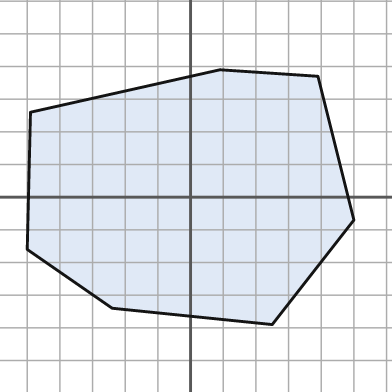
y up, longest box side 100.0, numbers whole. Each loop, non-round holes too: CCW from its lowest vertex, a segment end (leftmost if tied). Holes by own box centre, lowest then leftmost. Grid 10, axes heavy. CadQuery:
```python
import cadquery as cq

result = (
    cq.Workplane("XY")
    .moveTo(25.0, -39.0)
    .lineTo(50.0, -7.0)
    .lineTo(39.0, 37.0)
    .lineTo(9.0, 39.0)
    .lineTo(-49.0, 26.0)
    .lineTo(-50.0, -16.0)
    .lineTo(-24.0, -34.0)
    .close()
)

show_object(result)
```